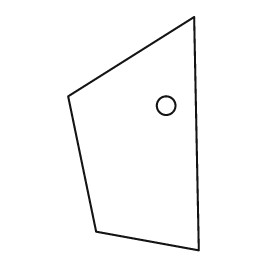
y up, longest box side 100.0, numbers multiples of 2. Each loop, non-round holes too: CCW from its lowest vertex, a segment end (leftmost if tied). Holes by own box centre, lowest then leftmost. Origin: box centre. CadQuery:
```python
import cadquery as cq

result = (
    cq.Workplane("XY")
    .moveTo(28.0, -50.0)
    .lineTo(26.0, 50.0)
    .lineTo(-28.0, 16.0)
    .lineTo(-16.0, -42.0)
    .close()
    .moveTo(14.0, 12.0)
    .circle(4.0)
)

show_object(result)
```